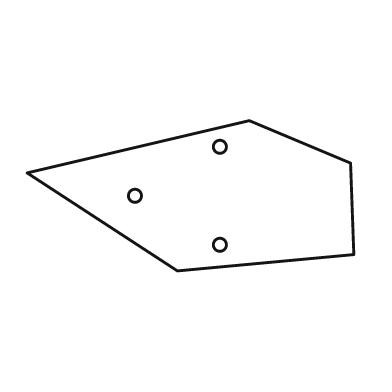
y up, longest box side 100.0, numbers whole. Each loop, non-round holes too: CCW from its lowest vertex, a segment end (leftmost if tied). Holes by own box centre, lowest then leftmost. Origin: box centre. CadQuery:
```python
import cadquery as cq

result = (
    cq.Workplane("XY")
    .moveTo(-4.0, -23.0)
    .lineTo(50.0, -18.0)
    .lineTo(49.0, 10.0)
    .lineTo(18.0, 23.0)
    .lineTo(-50.0, 7.0)
    .close()
    .moveTo(9.0, -15.0)
    .circle(2.0)
    .moveTo(-17.0, 0.0)
    .circle(2.0)
    .moveTo(9.0, 15.0)
    .circle(2.0)
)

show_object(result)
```